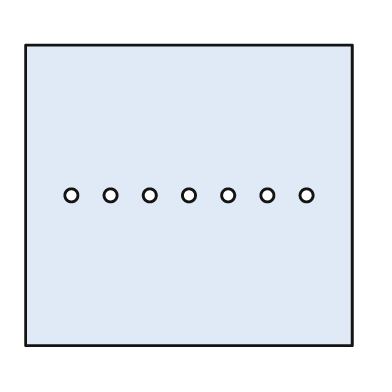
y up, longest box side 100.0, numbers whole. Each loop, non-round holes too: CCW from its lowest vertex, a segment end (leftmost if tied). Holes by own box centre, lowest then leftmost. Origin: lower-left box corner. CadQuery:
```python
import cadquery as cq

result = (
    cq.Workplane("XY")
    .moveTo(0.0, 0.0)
    .lineTo(100.0, 0.0)
    .lineTo(100.0, 92.0)
    .lineTo(0.0, 92.0)
    .close()
    .moveTo(14.0, 46.0)
    .circle(2.0)
    .moveTo(26.0, 46.0)
    .circle(2.0)
    .moveTo(38.0, 46.0)
    .circle(2.0)
    .moveTo(50.0, 46.0)
    .circle(2.0)
    .moveTo(62.0, 46.0)
    .circle(2.0)
    .moveTo(74.0, 46.0)
    .circle(2.0)
    .moveTo(86.0, 46.0)
    .circle(2.0)
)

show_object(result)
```